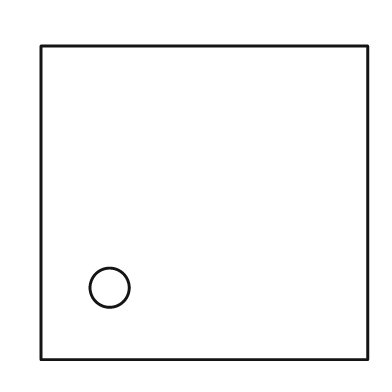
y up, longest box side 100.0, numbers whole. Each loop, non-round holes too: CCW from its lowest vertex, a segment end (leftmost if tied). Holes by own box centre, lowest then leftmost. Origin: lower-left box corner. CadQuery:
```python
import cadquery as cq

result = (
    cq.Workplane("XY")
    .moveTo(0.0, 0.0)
    .lineTo(100.0, 0.0)
    .lineTo(100.0, 96.0)
    .lineTo(0.0, 96.0)
    .close()
    .moveTo(21.0, 22.0)
    .circle(6.0)
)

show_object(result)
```